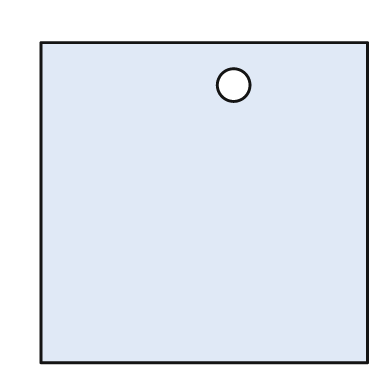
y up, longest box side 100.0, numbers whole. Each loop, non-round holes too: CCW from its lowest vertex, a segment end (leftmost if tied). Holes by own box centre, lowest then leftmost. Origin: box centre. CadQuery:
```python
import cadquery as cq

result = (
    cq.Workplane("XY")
    .moveTo(-50.0, -49.0)
    .lineTo(50.0, -49.0)
    .lineTo(50.0, 49.0)
    .lineTo(-50.0, 49.0)
    .close()
    .moveTo(9.0, 36.0)
    .circle(5.0)
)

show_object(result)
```